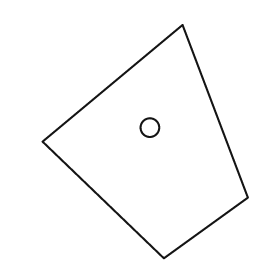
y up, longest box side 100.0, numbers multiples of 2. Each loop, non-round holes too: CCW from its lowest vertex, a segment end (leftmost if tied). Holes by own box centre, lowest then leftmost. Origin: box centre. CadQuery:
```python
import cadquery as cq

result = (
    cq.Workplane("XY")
    .moveTo(8.0, -50.0)
    .lineTo(44.0, -24.0)
    .lineTo(16.0, 50.0)
    .lineTo(-44.0, 0.0)
    .close()
    .moveTo(2.0, 6.0)
    .circle(4.0)
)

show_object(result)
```